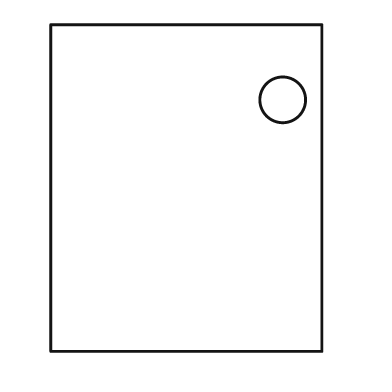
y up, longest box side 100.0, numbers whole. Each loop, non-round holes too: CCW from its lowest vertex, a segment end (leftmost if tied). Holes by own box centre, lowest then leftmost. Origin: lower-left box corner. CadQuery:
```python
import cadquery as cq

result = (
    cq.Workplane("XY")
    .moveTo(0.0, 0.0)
    .lineTo(83.0, 0.0)
    .lineTo(83.0, 100.0)
    .lineTo(0.0, 100.0)
    .close()
    .moveTo(71.0, 77.0)
    .circle(7.0)
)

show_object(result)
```